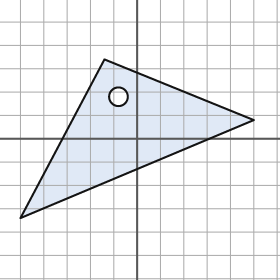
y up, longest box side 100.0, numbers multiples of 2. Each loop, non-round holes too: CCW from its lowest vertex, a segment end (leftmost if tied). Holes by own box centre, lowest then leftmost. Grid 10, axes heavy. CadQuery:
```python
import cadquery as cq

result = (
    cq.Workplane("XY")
    .moveTo(-50.0, -34.0)
    .lineTo(50.0, 8.0)
    .lineTo(-14.0, 34.0)
    .close()
    .moveTo(-8.0, 18.0)
    .circle(4.0)
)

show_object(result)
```